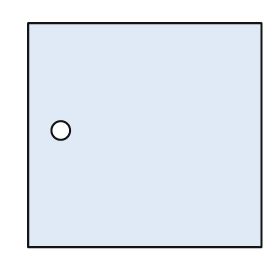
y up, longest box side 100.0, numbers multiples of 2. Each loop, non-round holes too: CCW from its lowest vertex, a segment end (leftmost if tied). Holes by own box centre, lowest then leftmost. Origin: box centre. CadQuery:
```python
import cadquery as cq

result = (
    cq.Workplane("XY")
    .moveTo(-50.0, -48.0)
    .lineTo(50.0, -48.0)
    .lineTo(50.0, 48.0)
    .lineTo(-50.0, 48.0)
    .close()
    .moveTo(-36.0, 2.0)
    .circle(4.0)
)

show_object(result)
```